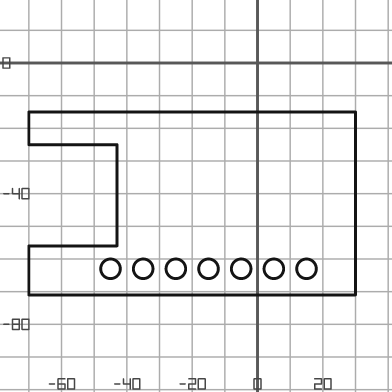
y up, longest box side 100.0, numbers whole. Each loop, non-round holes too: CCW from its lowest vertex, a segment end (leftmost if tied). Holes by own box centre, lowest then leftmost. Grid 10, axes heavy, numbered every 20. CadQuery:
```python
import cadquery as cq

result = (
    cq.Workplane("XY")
    .moveTo(-70.0, -71.0)
    .lineTo(30.0, -71.0)
    .lineTo(30.0, -15.0)
    .lineTo(-70.0, -15.0)
    .lineTo(-70.0, -25.0)
    .lineTo(-43.0, -25.0)
    .lineTo(-43.0, -56.0)
    .lineTo(-70.0, -56.0)
    .close()
    .moveTo(-45.0, -63.0)
    .circle(3.0)
    .moveTo(-35.0, -63.0)
    .circle(3.0)
    .moveTo(-25.0, -63.0)
    .circle(3.0)
    .moveTo(-15.0, -63.0)
    .circle(3.0)
    .moveTo(-5.0, -63.0)
    .circle(3.0)
    .moveTo(5.0, -63.0)
    .circle(3.0)
    .moveTo(15.0, -63.0)
    .circle(3.0)
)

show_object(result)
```